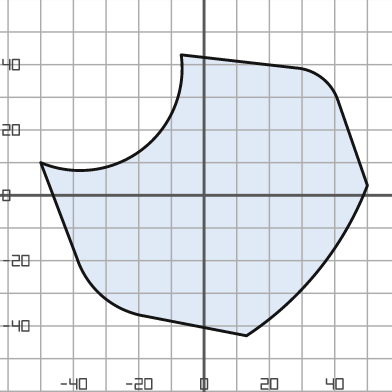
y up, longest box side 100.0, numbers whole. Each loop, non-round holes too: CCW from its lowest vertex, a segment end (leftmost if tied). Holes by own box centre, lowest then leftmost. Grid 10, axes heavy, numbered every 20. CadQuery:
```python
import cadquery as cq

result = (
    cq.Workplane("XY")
    .moveTo(13.0, -43.0)
    .threePointArc((35.0, -23.0), (50.0, 3.0))
    .lineTo(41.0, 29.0)
    .threePointArc((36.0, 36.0), (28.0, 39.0))
    .lineTo(-7.0, 43.0)
    .threePointArc((-19.0, 14.0), (-50.0, 10.0))
    .lineTo(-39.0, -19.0)
    .threePointArc((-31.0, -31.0), (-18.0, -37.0))
    .close()
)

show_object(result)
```